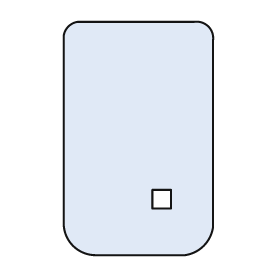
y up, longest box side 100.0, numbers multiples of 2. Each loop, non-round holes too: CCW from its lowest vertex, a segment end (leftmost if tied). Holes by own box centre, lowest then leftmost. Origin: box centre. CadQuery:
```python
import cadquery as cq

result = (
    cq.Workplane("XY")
    .moveTo(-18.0, -50.0)
    .lineTo(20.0, -50.0)
    .threePointArc((28.0, -46.0), (32.0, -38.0))
    .lineTo(32.0, 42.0)
    .threePointArc((30.0, 48.0), (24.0, 50.0))
    .lineTo(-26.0, 50.0)
    .threePointArc((-30.0, 48.0), (-32.0, 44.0))
    .lineTo(-32.0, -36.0)
    .threePointArc((-28.0, -46.0), (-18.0, -50.0))
    .close()
    .moveTo(6.0, -30.0)
    .lineTo(14.0, -30.0)
    .lineTo(14.0, -22.0)
    .lineTo(6.0, -22.0)
    .close()
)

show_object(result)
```